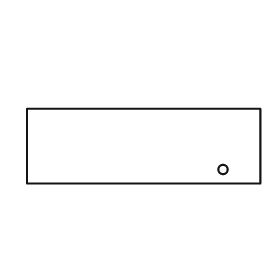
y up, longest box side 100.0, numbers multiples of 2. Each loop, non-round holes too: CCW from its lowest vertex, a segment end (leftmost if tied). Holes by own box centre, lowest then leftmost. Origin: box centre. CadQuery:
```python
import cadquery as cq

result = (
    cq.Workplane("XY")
    .moveTo(-50.0, -16.0)
    .lineTo(50.0, -16.0)
    .lineTo(50.0, 16.0)
    .lineTo(-50.0, 16.0)
    .close()
    .moveTo(34.0, -10.0)
    .circle(2.0)
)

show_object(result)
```